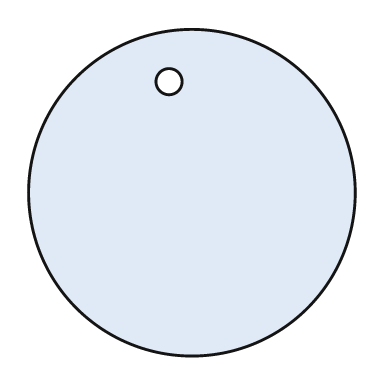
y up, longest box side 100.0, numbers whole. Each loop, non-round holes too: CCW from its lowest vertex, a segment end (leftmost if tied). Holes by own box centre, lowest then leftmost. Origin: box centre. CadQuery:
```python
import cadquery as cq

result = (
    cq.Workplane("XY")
    .moveTo(0.0, 0.0)
    .circle(50.0)
    .moveTo(-7.0, 34.0)
    .circle(4.0)
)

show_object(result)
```